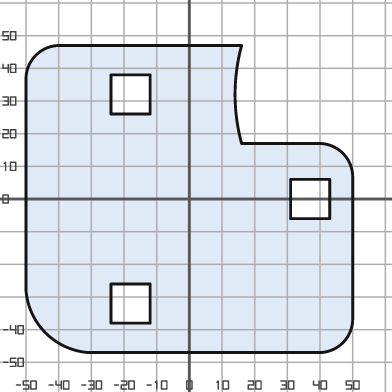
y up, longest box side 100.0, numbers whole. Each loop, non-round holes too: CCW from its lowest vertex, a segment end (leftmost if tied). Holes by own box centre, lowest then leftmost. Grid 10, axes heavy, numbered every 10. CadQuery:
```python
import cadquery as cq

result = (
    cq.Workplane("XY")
    .moveTo(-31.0, -47.0)
    .lineTo(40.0, -47.0)
    .threePointArc((47.0, -44.0), (50.0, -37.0))
    .lineTo(50.0, 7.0)
    .threePointArc((47.0, 14.0), (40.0, 17.0))
    .lineTo(16.0, 17.0)
    .threePointArc((14.0, 32.0), (16.0, 47.0))
    .lineTo(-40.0, 47.0)
    .threePointArc((-47.0, 44.0), (-50.0, 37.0))
    .lineTo(-50.0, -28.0)
    .threePointArc((-44.0, -41.0), (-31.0, -47.0))
    .close()
    .moveTo(-24.0, -38.0)
    .lineTo(-12.0, -38.0)
    .lineTo(-12.0, -26.0)
    .lineTo(-24.0, -26.0)
    .close()
    .moveTo(31.0, -6.0)
    .lineTo(43.0, -6.0)
    .lineTo(43.0, 6.0)
    .lineTo(31.0, 6.0)
    .close()
    .moveTo(-24.0, 26.0)
    .lineTo(-12.0, 26.0)
    .lineTo(-12.0, 38.0)
    .lineTo(-24.0, 38.0)
    .close()
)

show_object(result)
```